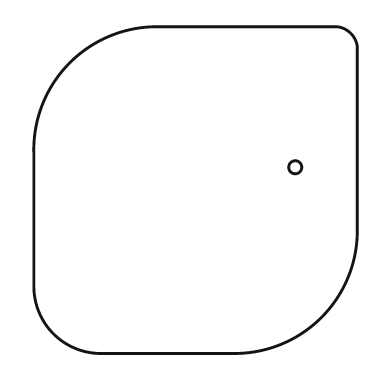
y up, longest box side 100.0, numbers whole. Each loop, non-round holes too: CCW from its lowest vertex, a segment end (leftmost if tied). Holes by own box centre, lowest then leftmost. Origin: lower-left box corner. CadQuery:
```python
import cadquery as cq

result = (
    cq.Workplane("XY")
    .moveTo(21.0, 0.0)
    .lineTo(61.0, 0.0)
    .threePointArc((88.0, 11.0), (99.0, 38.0))
    .lineTo(99.0, 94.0)
    .threePointArc((97.0, 98.0), (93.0, 100.0))
    .lineTo(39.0, 100.0)
    .threePointArc((11.0, 89.0), (0.0, 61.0))
    .lineTo(0.0, 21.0)
    .threePointArc((6.0, 6.0), (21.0, 0.0))
    .close()
    .moveTo(80.0, 57.0)
    .circle(2.0)
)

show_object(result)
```